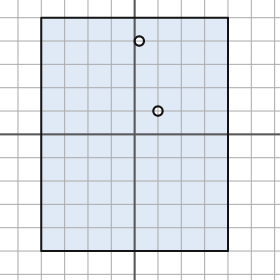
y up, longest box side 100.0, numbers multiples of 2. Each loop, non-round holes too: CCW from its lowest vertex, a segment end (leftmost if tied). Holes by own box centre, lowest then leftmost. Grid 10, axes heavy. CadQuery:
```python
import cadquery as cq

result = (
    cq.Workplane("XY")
    .moveTo(-40.0, -50.0)
    .lineTo(40.0, -50.0)
    .lineTo(40.0, 50.0)
    .lineTo(-40.0, 50.0)
    .close()
    .moveTo(10.0, 10.0)
    .circle(2.0)
    .moveTo(2.0, 40.0)
    .circle(2.0)
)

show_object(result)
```